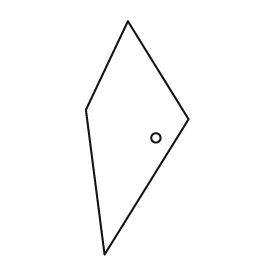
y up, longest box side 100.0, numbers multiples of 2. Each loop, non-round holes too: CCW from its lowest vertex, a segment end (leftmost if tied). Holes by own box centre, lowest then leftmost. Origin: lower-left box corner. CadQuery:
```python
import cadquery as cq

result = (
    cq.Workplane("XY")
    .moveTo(8.0, 0.0)
    .lineTo(44.0, 58.0)
    .lineTo(18.0, 100.0)
    .lineTo(0.0, 62.0)
    .close()
    .moveTo(30.0, 50.0)
    .circle(2.0)
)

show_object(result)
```